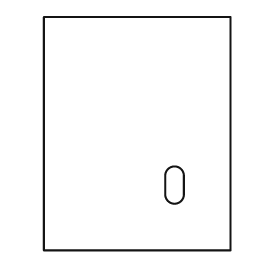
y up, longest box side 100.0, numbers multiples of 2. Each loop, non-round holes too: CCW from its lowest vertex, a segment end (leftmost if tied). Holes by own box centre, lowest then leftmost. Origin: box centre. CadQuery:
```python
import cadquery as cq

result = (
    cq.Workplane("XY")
    .moveTo(-40.0, -50.0)
    .lineTo(40.0, -50.0)
    .lineTo(40.0, 50.0)
    .lineTo(-40.0, 50.0)
    .close()
    .moveTo(12.0, -26.0)
    .threePointArc((16.0, -30.0), (20.0, -26.0))
    .lineTo(20.0, -18.0)
    .threePointArc((16.0, -14.0), (12.0, -18.0))
    .close()
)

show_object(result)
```